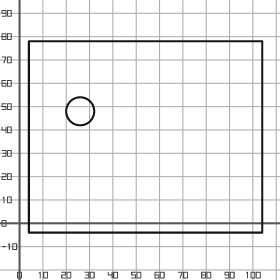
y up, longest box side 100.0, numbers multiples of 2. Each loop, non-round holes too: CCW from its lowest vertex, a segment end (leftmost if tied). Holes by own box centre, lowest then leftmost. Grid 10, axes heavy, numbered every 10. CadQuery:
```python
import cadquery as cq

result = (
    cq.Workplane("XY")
    .moveTo(4.0, -4.0)
    .lineTo(104.0, -4.0)
    .lineTo(104.0, 78.0)
    .lineTo(4.0, 78.0)
    .close()
    .moveTo(26.0, 48.0)
    .circle(6.0)
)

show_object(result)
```